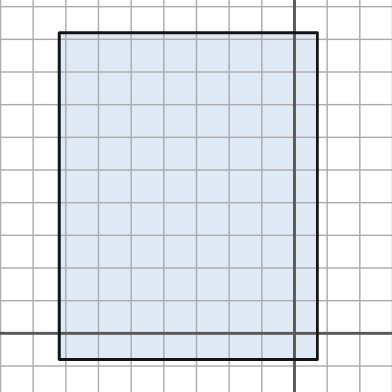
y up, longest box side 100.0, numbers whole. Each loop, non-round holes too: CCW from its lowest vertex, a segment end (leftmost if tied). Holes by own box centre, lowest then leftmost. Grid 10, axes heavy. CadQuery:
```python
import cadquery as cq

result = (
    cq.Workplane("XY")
    .moveTo(-72.0, -8.0)
    .lineTo(7.0, -8.0)
    .lineTo(7.0, 92.0)
    .lineTo(-72.0, 92.0)
    .close()
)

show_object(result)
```